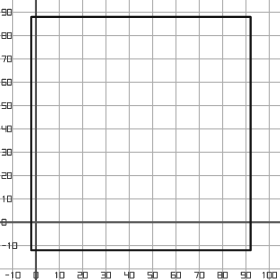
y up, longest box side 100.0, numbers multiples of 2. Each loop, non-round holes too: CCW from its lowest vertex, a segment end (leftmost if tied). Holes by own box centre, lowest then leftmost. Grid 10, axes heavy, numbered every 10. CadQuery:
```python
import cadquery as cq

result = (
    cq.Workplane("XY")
    .moveTo(-2.0, -12.0)
    .lineTo(92.0, -12.0)
    .lineTo(92.0, 88.0)
    .lineTo(-2.0, 88.0)
    .close()
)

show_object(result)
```